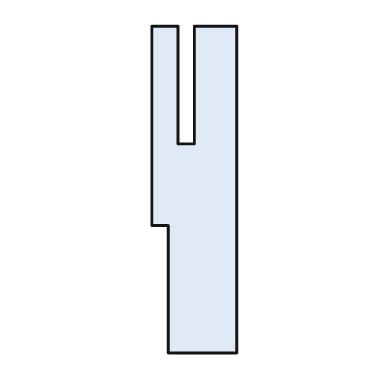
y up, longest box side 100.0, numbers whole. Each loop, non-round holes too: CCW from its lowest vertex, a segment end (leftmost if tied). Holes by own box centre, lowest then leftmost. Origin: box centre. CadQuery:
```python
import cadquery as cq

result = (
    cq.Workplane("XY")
    .moveTo(-8.0, -50.0)
    .lineTo(13.0, -50.0)
    .lineTo(13.0, 50.0)
    .lineTo(0.0, 50.0)
    .lineTo(0.0, 14.0)
    .lineTo(-5.0, 14.0)
    .lineTo(-5.0, 50.0)
    .lineTo(-13.0, 50.0)
    .lineTo(-13.0, -11.0)
    .lineTo(-8.0, -11.0)
    .close()
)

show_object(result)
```